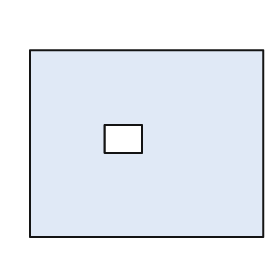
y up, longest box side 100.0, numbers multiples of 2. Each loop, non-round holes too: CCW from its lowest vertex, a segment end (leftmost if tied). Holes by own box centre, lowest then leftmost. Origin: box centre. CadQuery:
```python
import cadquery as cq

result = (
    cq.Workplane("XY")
    .moveTo(-50.0, -40.0)
    .lineTo(50.0, -40.0)
    .lineTo(50.0, 40.0)
    .lineTo(-50.0, 40.0)
    .close()
    .moveTo(-18.0, -4.0)
    .lineTo(-2.0, -4.0)
    .lineTo(-2.0, 8.0)
    .lineTo(-18.0, 8.0)
    .close()
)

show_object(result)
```